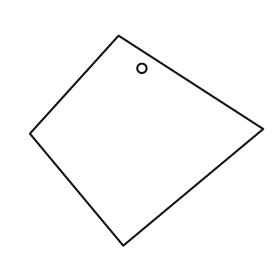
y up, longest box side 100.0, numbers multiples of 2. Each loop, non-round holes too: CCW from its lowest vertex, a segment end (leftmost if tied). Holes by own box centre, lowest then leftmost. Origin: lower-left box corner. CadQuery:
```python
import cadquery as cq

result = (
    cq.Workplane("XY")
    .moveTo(40.0, 0.0)
    .lineTo(100.0, 50.0)
    .lineTo(38.0, 90.0)
    .lineTo(0.0, 48.0)
    .close()
    .moveTo(48.0, 76.0)
    .circle(2.0)
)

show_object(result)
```